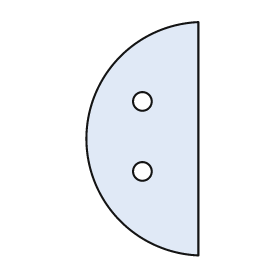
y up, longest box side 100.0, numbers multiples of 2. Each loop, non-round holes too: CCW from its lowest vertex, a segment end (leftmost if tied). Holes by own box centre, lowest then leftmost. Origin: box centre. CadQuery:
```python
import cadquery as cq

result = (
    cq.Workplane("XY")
    .moveTo(24.0, -50.0)
    .lineTo(24.0, 50.0)
    .threePointArc((-24.0, 0.0), (24.0, -50.0))
    .close()
    .moveTo(0.0, -14.0)
    .circle(4.0)
    .moveTo(0.0, 16.0)
    .circle(4.0)
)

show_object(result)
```